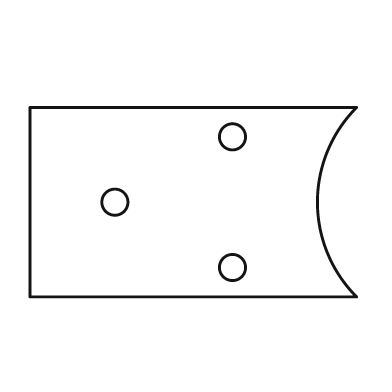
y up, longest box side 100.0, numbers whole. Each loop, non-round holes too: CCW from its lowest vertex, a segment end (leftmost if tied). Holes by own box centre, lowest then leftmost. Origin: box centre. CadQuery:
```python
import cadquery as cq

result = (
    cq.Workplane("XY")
    .moveTo(-50.0, -29.0)
    .lineTo(50.0, -29.0)
    .threePointArc((38.0, 0.0), (50.0, 29.0))
    .lineTo(-50.0, 29.0)
    .close()
    .moveTo(12.0, -20.0)
    .circle(4.0)
    .moveTo(-24.0, 0.0)
    .circle(4.0)
    .moveTo(12.0, 20.0)
    .circle(4.0)
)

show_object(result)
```